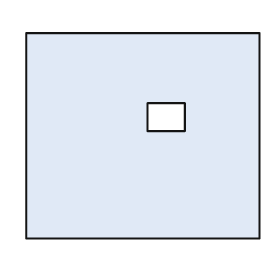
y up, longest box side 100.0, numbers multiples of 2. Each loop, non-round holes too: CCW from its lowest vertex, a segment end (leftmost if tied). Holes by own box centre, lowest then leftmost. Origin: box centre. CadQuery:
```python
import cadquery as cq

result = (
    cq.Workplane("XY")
    .moveTo(-50.0, -44.0)
    .lineTo(50.0, -44.0)
    .lineTo(50.0, 44.0)
    .lineTo(-50.0, 44.0)
    .close()
    .moveTo(2.0, 2.0)
    .lineTo(18.0, 2.0)
    .lineTo(18.0, 14.0)
    .lineTo(2.0, 14.0)
    .close()
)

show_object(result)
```